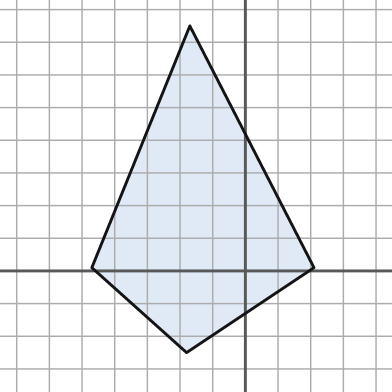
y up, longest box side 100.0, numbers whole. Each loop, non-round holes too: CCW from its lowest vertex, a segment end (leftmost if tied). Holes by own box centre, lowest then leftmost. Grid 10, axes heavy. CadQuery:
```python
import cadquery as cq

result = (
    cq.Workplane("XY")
    .moveTo(-18.0, -25.0)
    .lineTo(21.0, 1.0)
    .lineTo(-17.0, 75.0)
    .lineTo(-47.0, 1.0)
    .close()
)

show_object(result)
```